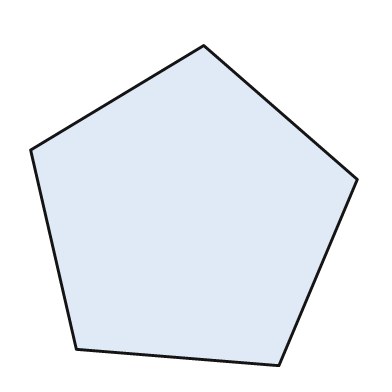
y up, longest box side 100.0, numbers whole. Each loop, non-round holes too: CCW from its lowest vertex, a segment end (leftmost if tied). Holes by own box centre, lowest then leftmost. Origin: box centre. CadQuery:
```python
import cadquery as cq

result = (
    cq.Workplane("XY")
    .moveTo(26.0, -49.0)
    .lineTo(50.0, 8.0)
    .lineTo(3.0, 49.0)
    .lineTo(-50.0, 17.0)
    .lineTo(-36.0, -44.0)
    .close()
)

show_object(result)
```